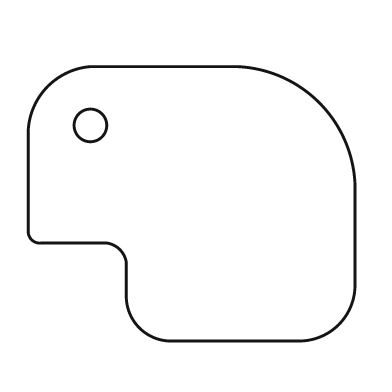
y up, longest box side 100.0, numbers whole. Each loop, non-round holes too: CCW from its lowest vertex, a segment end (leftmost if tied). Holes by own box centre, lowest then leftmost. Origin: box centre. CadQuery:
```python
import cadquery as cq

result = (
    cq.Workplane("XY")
    .moveTo(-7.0, -42.0)
    .lineTo(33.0, -42.0)
    .threePointArc((45.0, -37.0), (50.0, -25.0))
    .lineTo(50.0, 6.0)
    .threePointArc((39.0, 31.0), (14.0, 42.0))
    .lineTo(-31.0, 42.0)
    .threePointArc((-44.0, 36.0), (-50.0, 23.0))
    .lineTo(-50.0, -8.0)
    .threePointArc((-49.0, -11.0), (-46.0, -12.0))
    .lineTo(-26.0, -12.0)
    .threePointArc((-22.0, -14.0), (-20.0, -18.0))
    .lineTo(-20.0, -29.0)
    .threePointArc((-16.0, -38.0), (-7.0, -42.0))
    .close()
    .moveTo(-31.0, 24.0)
    .circle(5.0)
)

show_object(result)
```